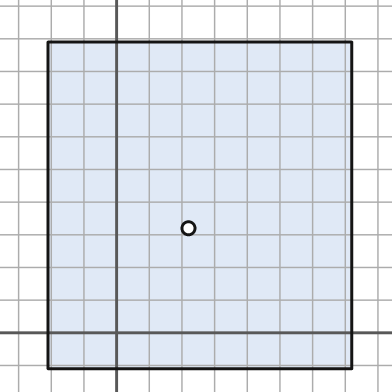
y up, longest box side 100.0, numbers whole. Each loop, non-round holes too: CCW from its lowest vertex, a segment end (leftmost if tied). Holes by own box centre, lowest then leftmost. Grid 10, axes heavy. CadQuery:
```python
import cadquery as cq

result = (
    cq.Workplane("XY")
    .moveTo(-21.0, -11.0)
    .lineTo(72.0, -11.0)
    .lineTo(72.0, 89.0)
    .lineTo(-21.0, 89.0)
    .close()
    .moveTo(22.0, 32.0)
    .circle(2.0)
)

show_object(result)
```